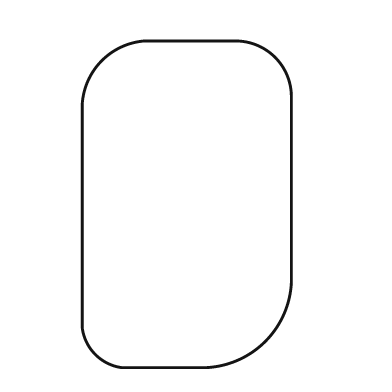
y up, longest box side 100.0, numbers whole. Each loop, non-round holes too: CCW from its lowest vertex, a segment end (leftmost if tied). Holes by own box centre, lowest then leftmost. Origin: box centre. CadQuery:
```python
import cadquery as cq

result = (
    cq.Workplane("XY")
    .moveTo(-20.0, -50.0)
    .lineTo(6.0, -50.0)
    .threePointArc((24.0, -42.0), (32.0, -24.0))
    .lineTo(32.0, 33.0)
    .threePointArc((27.0, 45.0), (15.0, 50.0))
    .lineTo(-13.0, 50.0)
    .threePointArc((-26.0, 44.0), (-32.0, 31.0))
    .lineTo(-32.0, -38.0)
    .threePointArc((-28.0, -46.0), (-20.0, -50.0))
    .close()
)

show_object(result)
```